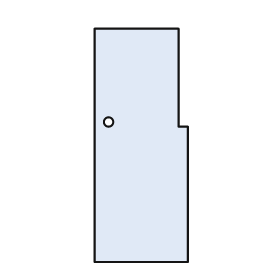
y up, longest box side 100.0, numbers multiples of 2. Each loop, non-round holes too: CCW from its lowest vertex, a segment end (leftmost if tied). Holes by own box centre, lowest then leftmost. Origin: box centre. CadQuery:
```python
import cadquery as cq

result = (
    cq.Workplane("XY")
    .moveTo(-20.0, -50.0)
    .lineTo(20.0, -50.0)
    .lineTo(20.0, 8.0)
    .lineTo(16.0, 8.0)
    .lineTo(16.0, 50.0)
    .lineTo(-20.0, 50.0)
    .close()
    .moveTo(-14.0, 10.0)
    .circle(2.0)
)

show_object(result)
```